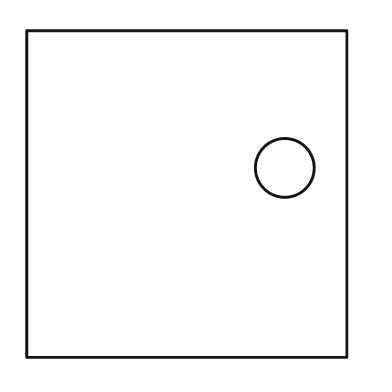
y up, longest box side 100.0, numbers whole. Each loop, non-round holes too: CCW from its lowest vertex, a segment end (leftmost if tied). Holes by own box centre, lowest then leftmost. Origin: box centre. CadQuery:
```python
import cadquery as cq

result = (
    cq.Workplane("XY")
    .moveTo(-49.0, -50.0)
    .lineTo(49.0, -50.0)
    .lineTo(49.0, 50.0)
    .lineTo(-49.0, 50.0)
    .close()
    .moveTo(30.0, 8.0)
    .circle(9.0)
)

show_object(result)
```